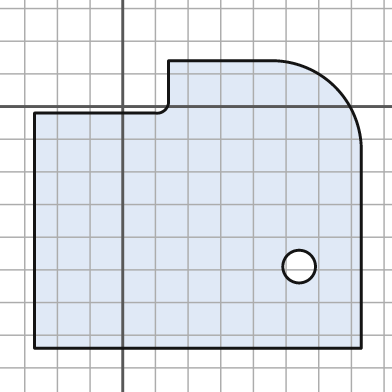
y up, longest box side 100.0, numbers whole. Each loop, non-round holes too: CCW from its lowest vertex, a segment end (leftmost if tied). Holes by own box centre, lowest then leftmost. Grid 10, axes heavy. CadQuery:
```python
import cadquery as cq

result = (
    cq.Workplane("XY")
    .moveTo(-27.0, -74.0)
    .lineTo(73.0, -74.0)
    .lineTo(73.0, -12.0)
    .threePointArc((65.0, 6.0), (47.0, 14.0))
    .lineTo(14.0, 14.0)
    .lineTo(14.0, 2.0)
    .threePointArc((13.0, -1.0), (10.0, -2.0))
    .lineTo(-27.0, -2.0)
    .close()
    .moveTo(54.0, -49.0)
    .circle(5.0)
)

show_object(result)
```